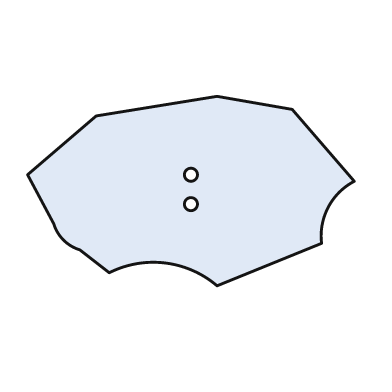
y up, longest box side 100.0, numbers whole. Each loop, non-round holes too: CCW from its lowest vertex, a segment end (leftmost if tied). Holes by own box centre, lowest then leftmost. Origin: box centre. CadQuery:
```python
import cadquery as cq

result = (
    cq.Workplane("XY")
    .moveTo(8.0, -29.0)
    .lineTo(40.0, -16.0)
    .threePointArc((42.0, -5.0), (50.0, 3.0))
    .lineTo(31.0, 25.0)
    .lineTo(8.0, 29.0)
    .lineTo(-29.0, 23.0)
    .lineTo(-50.0, 5.0)
    .lineTo(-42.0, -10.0)
    .threePointArc((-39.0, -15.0), (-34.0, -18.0))
    .lineTo(-25.0, -25.0)
    .threePointArc((-8.0, -22.0), (8.0, -29.0))
    .close()
    .moveTo(0.0, -4.0)
    .circle(2.0)
    .moveTo(0.0, 5.0)
    .circle(2.0)
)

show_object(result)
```